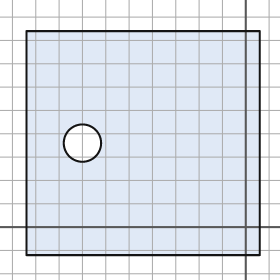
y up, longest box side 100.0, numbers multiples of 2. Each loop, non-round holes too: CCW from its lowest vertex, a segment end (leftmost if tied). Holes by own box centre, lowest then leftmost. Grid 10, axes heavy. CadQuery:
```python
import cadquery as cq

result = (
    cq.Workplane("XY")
    .moveTo(-94.0, -12.0)
    .lineTo(6.0, -12.0)
    .lineTo(6.0, 84.0)
    .lineTo(-94.0, 84.0)
    .close()
    .moveTo(-70.0, 36.0)
    .circle(8.0)
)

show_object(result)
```